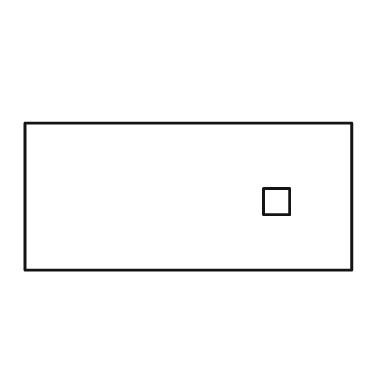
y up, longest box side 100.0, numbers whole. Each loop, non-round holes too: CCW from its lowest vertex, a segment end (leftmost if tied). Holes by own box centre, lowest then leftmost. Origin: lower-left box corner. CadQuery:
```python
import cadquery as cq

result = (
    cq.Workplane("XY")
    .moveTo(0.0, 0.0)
    .lineTo(100.0, 0.0)
    .lineTo(100.0, 45.0)
    .lineTo(0.0, 45.0)
    .close()
    .moveTo(73.0, 17.0)
    .lineTo(81.0, 17.0)
    .lineTo(81.0, 25.0)
    .lineTo(73.0, 25.0)
    .close()
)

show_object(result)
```